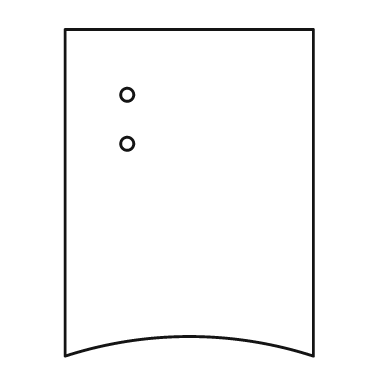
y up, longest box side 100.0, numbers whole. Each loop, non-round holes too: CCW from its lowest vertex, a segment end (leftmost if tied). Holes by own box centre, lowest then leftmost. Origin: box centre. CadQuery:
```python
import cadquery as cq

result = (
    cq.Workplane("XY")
    .moveTo(-38.0, -50.0)
    .threePointArc((0.0, -44.0), (38.0, -50.0))
    .lineTo(38.0, 50.0)
    .lineTo(-38.0, 50.0)
    .close()
    .moveTo(-19.0, 15.0)
    .circle(2.0)
    .moveTo(-19.0, 30.0)
    .circle(2.0)
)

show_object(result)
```